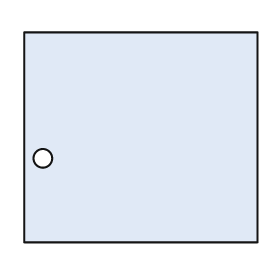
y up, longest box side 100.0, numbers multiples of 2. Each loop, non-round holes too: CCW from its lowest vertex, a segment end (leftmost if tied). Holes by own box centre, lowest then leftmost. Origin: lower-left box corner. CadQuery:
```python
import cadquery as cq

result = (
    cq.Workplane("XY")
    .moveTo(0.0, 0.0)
    .lineTo(100.0, 0.0)
    .lineTo(100.0, 90.0)
    .lineTo(0.0, 90.0)
    .close()
    .moveTo(8.0, 36.0)
    .circle(4.0)
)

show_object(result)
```